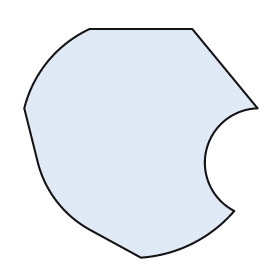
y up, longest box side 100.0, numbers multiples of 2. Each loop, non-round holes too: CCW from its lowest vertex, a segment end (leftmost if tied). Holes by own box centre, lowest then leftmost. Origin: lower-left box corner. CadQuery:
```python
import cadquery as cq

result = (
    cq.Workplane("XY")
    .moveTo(50.0, 0.0)
    .threePointArc((72.0, 6.0), (90.0, 20.0))
    .threePointArc((78.0, 46.0), (100.0, 64.0))
    .lineTo(72.0, 98.0)
    .lineTo(28.0, 98.0)
    .threePointArc((10.0, 84.0), (0.0, 64.0))
    .lineTo(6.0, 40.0)
    .threePointArc((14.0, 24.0), (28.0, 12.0))
    .close()
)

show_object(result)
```